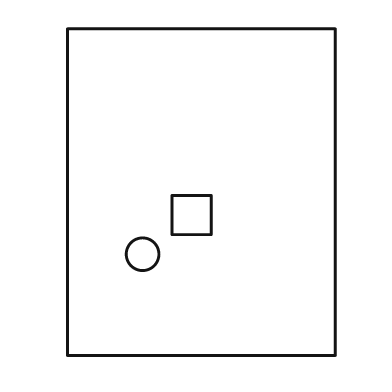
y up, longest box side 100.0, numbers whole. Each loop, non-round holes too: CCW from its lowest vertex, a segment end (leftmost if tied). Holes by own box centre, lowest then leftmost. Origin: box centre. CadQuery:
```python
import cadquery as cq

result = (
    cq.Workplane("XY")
    .moveTo(-41.0, -50.0)
    .lineTo(41.0, -50.0)
    .lineTo(41.0, 50.0)
    .lineTo(-41.0, 50.0)
    .close()
    .moveTo(-18.0, -19.0)
    .circle(5.0)
    .moveTo(-9.0, -13.0)
    .lineTo(3.0, -13.0)
    .lineTo(3.0, -1.0)
    .lineTo(-9.0, -1.0)
    .close()
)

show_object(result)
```